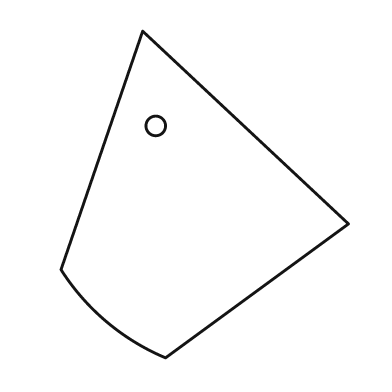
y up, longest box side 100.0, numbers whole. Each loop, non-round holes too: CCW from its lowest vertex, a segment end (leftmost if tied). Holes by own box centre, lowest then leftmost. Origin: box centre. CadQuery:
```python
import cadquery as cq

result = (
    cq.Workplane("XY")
    .moveTo(-12.0, -50.0)
    .lineTo(44.0, -9.0)
    .lineTo(-19.0, 50.0)
    .lineTo(-44.0, -23.0)
    .threePointArc((-30.0, -39.0), (-12.0, -50.0))
    .close()
    .moveTo(-15.0, 21.0)
    .circle(3.0)
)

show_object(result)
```